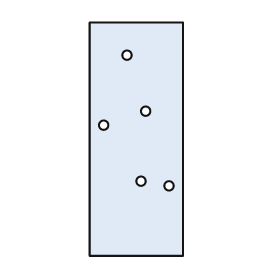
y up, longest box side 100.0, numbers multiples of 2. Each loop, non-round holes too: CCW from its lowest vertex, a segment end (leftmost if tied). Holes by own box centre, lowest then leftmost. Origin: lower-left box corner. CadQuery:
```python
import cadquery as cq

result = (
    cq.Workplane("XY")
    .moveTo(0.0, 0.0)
    .lineTo(40.0, 0.0)
    .lineTo(40.0, 100.0)
    .lineTo(0.0, 100.0)
    .close()
    .moveTo(34.0, 30.0)
    .circle(2.0)
    .moveTo(22.0, 32.0)
    .circle(2.0)
    .moveTo(6.0, 56.0)
    .circle(2.0)
    .moveTo(24.0, 62.0)
    .circle(2.0)
    .moveTo(16.0, 86.0)
    .circle(2.0)
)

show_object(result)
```